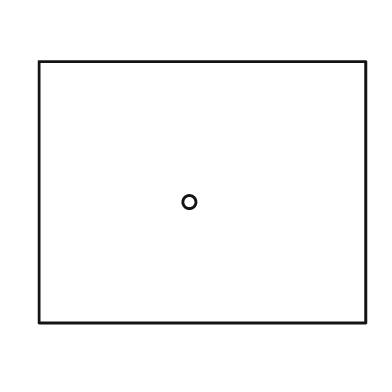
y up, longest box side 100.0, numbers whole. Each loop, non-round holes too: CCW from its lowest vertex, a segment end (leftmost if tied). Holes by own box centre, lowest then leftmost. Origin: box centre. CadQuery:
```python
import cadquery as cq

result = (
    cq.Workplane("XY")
    .moveTo(-50.0, -40.0)
    .lineTo(50.0, -40.0)
    .lineTo(50.0, 40.0)
    .lineTo(-50.0, 40.0)
    .close()
    .moveTo(-4.0, -3.0)
    .circle(2.0)
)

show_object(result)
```